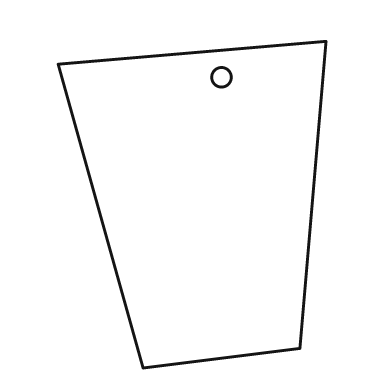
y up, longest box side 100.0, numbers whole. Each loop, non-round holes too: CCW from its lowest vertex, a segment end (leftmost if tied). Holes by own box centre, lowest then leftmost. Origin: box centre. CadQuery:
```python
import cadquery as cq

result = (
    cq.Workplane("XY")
    .moveTo(-15.0, -50.0)
    .lineTo(33.0, -44.0)
    .lineTo(41.0, 50.0)
    .lineTo(-41.0, 43.0)
    .close()
    .moveTo(9.0, 39.0)
    .circle(3.0)
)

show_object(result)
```